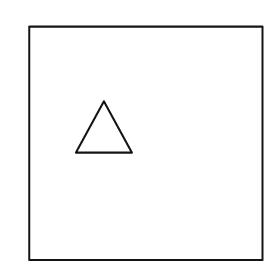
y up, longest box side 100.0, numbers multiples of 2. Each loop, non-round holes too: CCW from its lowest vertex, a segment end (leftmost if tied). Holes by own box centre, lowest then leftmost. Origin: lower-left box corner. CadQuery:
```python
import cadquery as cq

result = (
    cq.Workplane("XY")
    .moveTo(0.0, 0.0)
    .lineTo(100.0, 0.0)
    .lineTo(100.0, 100.0)
    .lineTo(0.0, 100.0)
    .close()
    .moveTo(20.0, 46.0)
    .lineTo(44.0, 46.0)
    .lineTo(32.0, 68.0)
    .close()
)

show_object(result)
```